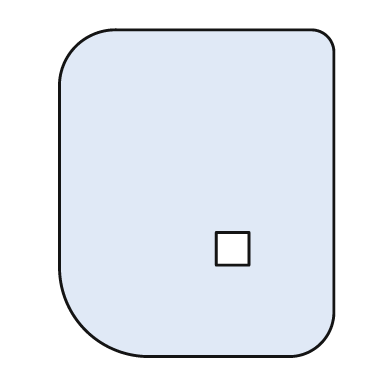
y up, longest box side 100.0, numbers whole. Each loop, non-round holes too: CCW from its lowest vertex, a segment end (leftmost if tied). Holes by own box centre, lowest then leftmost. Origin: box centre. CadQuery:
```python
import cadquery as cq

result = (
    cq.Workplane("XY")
    .moveTo(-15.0, -50.0)
    .lineTo(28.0, -50.0)
    .threePointArc((38.0, -46.0), (42.0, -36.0))
    .lineTo(42.0, 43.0)
    .threePointArc((40.0, 48.0), (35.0, 50.0))
    .lineTo(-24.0, 50.0)
    .threePointArc((-37.0, 45.0), (-42.0, 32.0))
    .lineTo(-42.0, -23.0)
    .threePointArc((-34.0, -42.0), (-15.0, -50.0))
    .close()
    .moveTo(6.0, -22.0)
    .lineTo(16.0, -22.0)
    .lineTo(16.0, -12.0)
    .lineTo(6.0, -12.0)
    .close()
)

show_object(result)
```